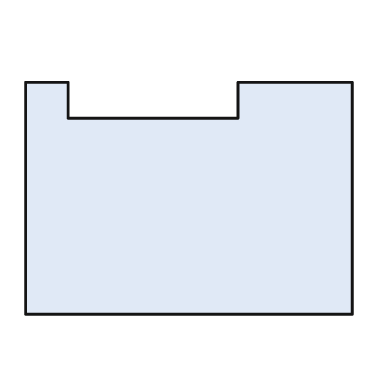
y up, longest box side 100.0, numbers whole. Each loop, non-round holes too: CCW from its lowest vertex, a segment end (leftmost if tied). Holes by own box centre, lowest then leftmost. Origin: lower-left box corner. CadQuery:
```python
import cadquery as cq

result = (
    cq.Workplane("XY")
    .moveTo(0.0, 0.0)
    .lineTo(100.0, 0.0)
    .lineTo(100.0, 71.0)
    .lineTo(65.0, 71.0)
    .lineTo(65.0, 60.0)
    .lineTo(13.0, 60.0)
    .lineTo(13.0, 71.0)
    .lineTo(0.0, 71.0)
    .close()
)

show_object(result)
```